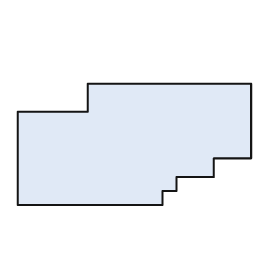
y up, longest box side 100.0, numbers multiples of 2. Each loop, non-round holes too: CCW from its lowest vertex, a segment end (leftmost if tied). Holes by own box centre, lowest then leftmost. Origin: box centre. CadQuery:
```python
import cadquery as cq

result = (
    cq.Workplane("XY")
    .moveTo(-50.0, -26.0)
    .lineTo(12.0, -26.0)
    .lineTo(12.0, -20.0)
    .lineTo(18.0, -20.0)
    .lineTo(18.0, -14.0)
    .lineTo(34.0, -14.0)
    .lineTo(34.0, -6.0)
    .lineTo(50.0, -6.0)
    .lineTo(50.0, 26.0)
    .lineTo(-20.0, 26.0)
    .lineTo(-20.0, 14.0)
    .lineTo(-50.0, 14.0)
    .close()
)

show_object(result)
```